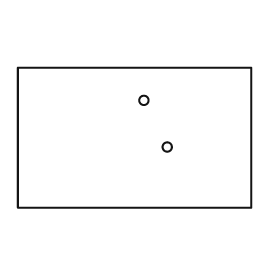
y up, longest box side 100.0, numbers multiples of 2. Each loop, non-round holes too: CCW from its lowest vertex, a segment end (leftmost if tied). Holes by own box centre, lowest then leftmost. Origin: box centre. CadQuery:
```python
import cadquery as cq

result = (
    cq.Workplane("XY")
    .moveTo(-50.0, -30.0)
    .lineTo(50.0, -30.0)
    .lineTo(50.0, 30.0)
    .lineTo(-50.0, 30.0)
    .close()
    .moveTo(14.0, -4.0)
    .circle(2.0)
    .moveTo(4.0, 16.0)
    .circle(2.0)
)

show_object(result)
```